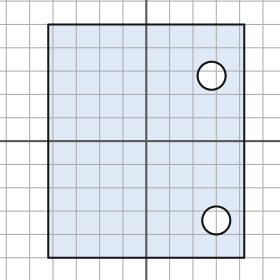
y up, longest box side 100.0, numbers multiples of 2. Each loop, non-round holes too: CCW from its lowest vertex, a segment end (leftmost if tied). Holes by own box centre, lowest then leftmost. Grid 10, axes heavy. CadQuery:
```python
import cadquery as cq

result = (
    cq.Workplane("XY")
    .moveTo(-42.0, -50.0)
    .lineTo(42.0, -50.0)
    .lineTo(42.0, 50.0)
    .lineTo(-42.0, 50.0)
    .close()
    .moveTo(30.0, -34.0)
    .circle(6.0)
    .moveTo(28.0, 28.0)
    .circle(6.0)
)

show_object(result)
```